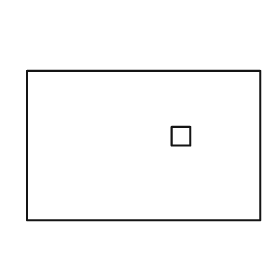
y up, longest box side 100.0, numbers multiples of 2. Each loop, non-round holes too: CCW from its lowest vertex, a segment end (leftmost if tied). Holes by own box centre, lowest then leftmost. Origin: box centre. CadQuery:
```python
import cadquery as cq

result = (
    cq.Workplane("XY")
    .moveTo(-50.0, -32.0)
    .lineTo(50.0, -32.0)
    .lineTo(50.0, 32.0)
    .lineTo(-50.0, 32.0)
    .close()
    .moveTo(12.0, 0.0)
    .lineTo(20.0, 0.0)
    .lineTo(20.0, 8.0)
    .lineTo(12.0, 8.0)
    .close()
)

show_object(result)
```